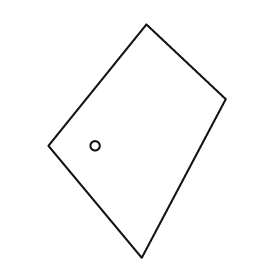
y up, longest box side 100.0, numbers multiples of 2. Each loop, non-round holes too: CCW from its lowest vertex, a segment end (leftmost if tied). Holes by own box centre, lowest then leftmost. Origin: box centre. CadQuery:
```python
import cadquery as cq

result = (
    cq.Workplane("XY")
    .moveTo(2.0, -50.0)
    .lineTo(38.0, 18.0)
    .lineTo(4.0, 50.0)
    .lineTo(-38.0, -2.0)
    .close()
    .moveTo(-18.0, -2.0)
    .circle(2.0)
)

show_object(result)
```